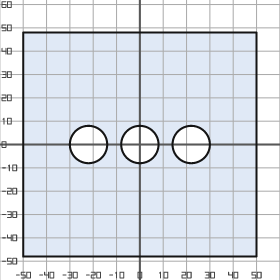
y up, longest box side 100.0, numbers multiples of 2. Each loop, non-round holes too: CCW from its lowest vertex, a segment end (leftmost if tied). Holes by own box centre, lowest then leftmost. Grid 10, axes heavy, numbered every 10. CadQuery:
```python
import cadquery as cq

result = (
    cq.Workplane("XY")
    .moveTo(-50.0, -48.0)
    .lineTo(50.0, -48.0)
    .lineTo(50.0, 48.0)
    .lineTo(-50.0, 48.0)
    .close()
    .moveTo(-22.0, 0.0)
    .circle(8.0)
    .moveTo(0.0, 0.0)
    .circle(8.0)
    .moveTo(22.0, 0.0)
    .circle(8.0)
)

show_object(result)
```